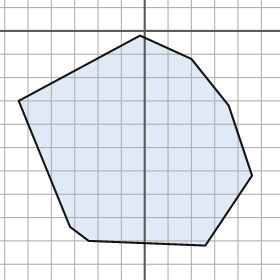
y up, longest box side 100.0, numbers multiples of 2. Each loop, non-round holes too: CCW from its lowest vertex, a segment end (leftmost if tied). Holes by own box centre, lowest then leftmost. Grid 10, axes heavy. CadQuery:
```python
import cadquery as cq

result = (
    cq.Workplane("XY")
    .moveTo(26.0, -92.0)
    .lineTo(46.0, -62.0)
    .lineTo(36.0, -32.0)
    .lineTo(20.0, -12.0)
    .lineTo(-2.0, -2.0)
    .lineTo(-54.0, -30.0)
    .lineTo(-32.0, -84.0)
    .lineTo(-24.0, -90.0)
    .close()
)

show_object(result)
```